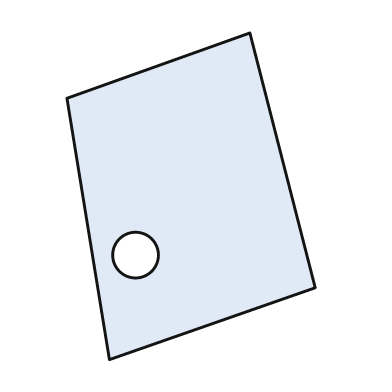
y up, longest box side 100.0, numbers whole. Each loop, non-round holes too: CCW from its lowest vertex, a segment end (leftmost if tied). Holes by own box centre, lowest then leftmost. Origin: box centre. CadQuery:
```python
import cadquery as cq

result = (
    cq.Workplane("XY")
    .moveTo(-25.0, -50.0)
    .lineTo(38.0, -28.0)
    .lineTo(18.0, 50.0)
    .lineTo(-38.0, 30.0)
    .close()
    .moveTo(-17.0, -18.0)
    .circle(7.0)
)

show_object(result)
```